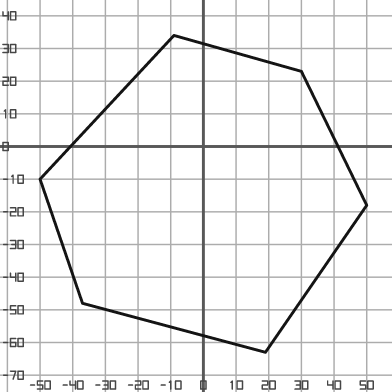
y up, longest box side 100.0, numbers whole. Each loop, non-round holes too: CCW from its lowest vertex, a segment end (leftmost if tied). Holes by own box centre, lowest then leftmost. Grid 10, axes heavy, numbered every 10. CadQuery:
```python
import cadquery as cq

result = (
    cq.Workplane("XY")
    .moveTo(19.0, -63.0)
    .lineTo(50.0, -18.0)
    .lineTo(30.0, 23.0)
    .lineTo(-9.0, 34.0)
    .lineTo(-50.0, -10.0)
    .lineTo(-37.0, -48.0)
    .close()
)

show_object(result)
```